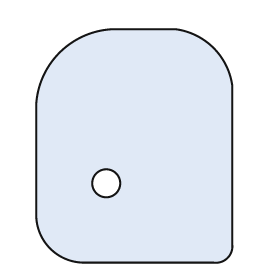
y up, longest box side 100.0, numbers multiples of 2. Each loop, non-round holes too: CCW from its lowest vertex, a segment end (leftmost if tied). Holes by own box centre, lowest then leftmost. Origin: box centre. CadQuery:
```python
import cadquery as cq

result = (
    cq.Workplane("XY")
    .moveTo(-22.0, -50.0)
    .lineTo(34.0, -50.0)
    .threePointArc((40.0, -48.0), (42.0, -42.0))
    .lineTo(42.0, 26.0)
    .threePointArc((34.0, 42.0), (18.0, 50.0))
    .lineTo(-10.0, 50.0)
    .threePointArc((-32.0, 40.0), (-42.0, 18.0))
    .lineTo(-42.0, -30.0)
    .threePointArc((-36.0, -44.0), (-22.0, -50.0))
    .close()
    .moveTo(-12.0, -16.0)
    .circle(6.0)
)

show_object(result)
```